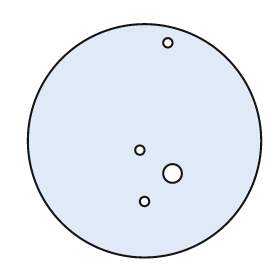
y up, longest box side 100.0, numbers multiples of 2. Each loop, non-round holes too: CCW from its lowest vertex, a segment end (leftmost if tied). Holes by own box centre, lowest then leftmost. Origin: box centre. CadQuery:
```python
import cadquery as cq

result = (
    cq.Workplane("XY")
    .moveTo(0.0, 0.0)
    .circle(50.0)
    .moveTo(0.0, -26.0)
    .circle(2.0)
    .moveTo(12.0, -14.0)
    .circle(4.0)
    .moveTo(-2.0, -4.0)
    .circle(2.0)
    .moveTo(10.0, 42.0)
    .circle(2.0)
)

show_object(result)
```